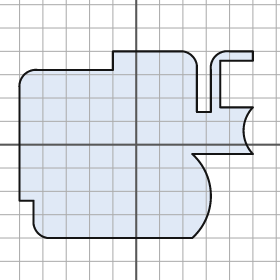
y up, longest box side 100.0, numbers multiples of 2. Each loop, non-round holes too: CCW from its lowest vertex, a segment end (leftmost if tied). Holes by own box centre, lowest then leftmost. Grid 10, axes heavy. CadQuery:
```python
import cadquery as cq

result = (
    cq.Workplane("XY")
    .moveTo(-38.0, -40.0)
    .lineTo(24.0, -40.0)
    .threePointArc((32.0, -22.0), (24.0, -4.0))
    .lineTo(50.0, -4.0)
    .threePointArc((46.0, 6.0), (50.0, 16.0))
    .lineTo(36.0, 16.0)
    .lineTo(36.0, 36.0)
    .lineTo(50.0, 36.0)
    .lineTo(50.0, 40.0)
    .lineTo(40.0, 40.0)
    .threePointArc((34.0, 38.0), (32.0, 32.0))
    .lineTo(32.0, 14.0)
    .lineTo(26.0, 14.0)
    .lineTo(26.0, 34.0)
    .threePointArc((24.0, 38.0), (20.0, 40.0))
    .lineTo(-10.0, 40.0)
    .lineTo(-10.0, 32.0)
    .lineTo(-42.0, 32.0)
    .threePointArc((-48.0, 30.0), (-50.0, 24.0))
    .lineTo(-50.0, -24.0)
    .lineTo(-44.0, -24.0)
    .lineTo(-44.0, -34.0)
    .threePointArc((-42.0, -38.0), (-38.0, -40.0))
    .close()
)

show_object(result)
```